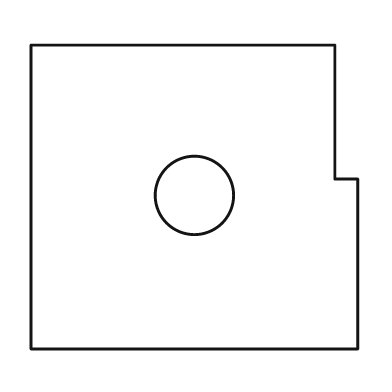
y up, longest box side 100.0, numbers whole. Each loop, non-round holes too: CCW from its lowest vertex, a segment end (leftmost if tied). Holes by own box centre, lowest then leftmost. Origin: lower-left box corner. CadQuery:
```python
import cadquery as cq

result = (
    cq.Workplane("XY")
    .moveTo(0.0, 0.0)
    .lineTo(100.0, 0.0)
    .lineTo(100.0, 52.0)
    .lineTo(93.0, 52.0)
    .lineTo(93.0, 93.0)
    .lineTo(0.0, 93.0)
    .close()
    .moveTo(50.0, 47.0)
    .circle(12.0)
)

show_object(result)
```